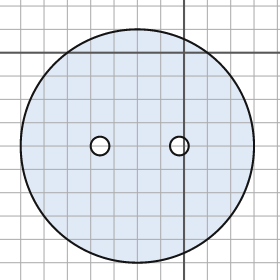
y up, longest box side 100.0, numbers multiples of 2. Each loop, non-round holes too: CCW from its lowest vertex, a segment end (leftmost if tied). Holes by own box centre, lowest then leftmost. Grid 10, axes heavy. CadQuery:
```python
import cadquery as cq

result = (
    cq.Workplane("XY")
    .moveTo(-20.0, -40.0)
    .circle(50.0)
    .moveTo(-36.0, -40.0)
    .circle(4.0)
    .moveTo(-2.0, -40.0)
    .circle(4.0)
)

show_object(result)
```